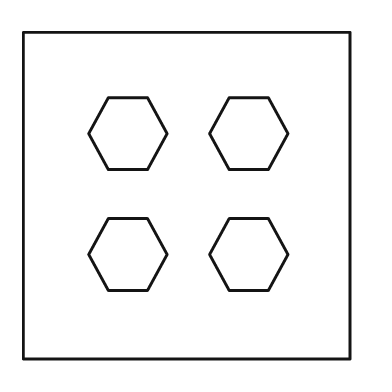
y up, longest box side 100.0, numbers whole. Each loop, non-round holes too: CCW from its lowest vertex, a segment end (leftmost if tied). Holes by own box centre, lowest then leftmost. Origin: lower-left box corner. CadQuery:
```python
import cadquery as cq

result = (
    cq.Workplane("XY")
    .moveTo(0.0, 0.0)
    .lineTo(100.0, 0.0)
    .lineTo(100.0, 100.0)
    .lineTo(0.0, 100.0)
    .close()
    .moveTo(26.0, 21.0)
    .lineTo(38.0, 21.0)
    .lineTo(44.0, 32.0)
    .lineTo(38.0, 43.0)
    .lineTo(26.0, 43.0)
    .lineTo(20.0, 32.0)
    .close()
    .moveTo(63.0, 21.0)
    .lineTo(75.0, 21.0)
    .lineTo(81.0, 32.0)
    .lineTo(75.0, 43.0)
    .lineTo(63.0, 43.0)
    .lineTo(57.0, 32.0)
    .close()
    .moveTo(26.0, 58.0)
    .lineTo(38.0, 58.0)
    .lineTo(44.0, 69.0)
    .lineTo(38.0, 80.0)
    .lineTo(26.0, 80.0)
    .lineTo(20.0, 69.0)
    .close()
    .moveTo(63.0, 58.0)
    .lineTo(75.0, 58.0)
    .lineTo(81.0, 69.0)
    .lineTo(75.0, 80.0)
    .lineTo(63.0, 80.0)
    .lineTo(57.0, 69.0)
    .close()
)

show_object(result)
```